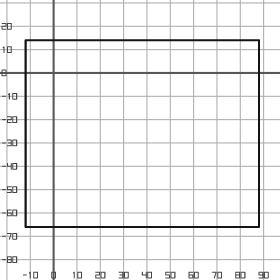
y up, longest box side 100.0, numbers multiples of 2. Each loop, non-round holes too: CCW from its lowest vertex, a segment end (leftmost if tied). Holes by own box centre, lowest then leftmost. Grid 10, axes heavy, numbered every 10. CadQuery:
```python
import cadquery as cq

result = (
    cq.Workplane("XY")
    .moveTo(-12.0, -66.0)
    .lineTo(88.0, -66.0)
    .lineTo(88.0, 14.0)
    .lineTo(-12.0, 14.0)
    .close()
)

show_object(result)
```